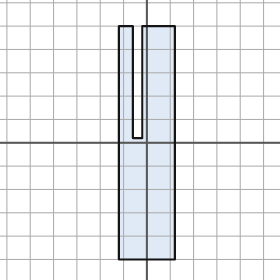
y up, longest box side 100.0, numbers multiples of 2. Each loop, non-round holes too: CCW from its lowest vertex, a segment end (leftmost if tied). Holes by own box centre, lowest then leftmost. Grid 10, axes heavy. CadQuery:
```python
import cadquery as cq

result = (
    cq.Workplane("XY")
    .moveTo(-12.0, -50.0)
    .lineTo(12.0, -50.0)
    .lineTo(12.0, 50.0)
    .lineTo(-2.0, 50.0)
    .lineTo(-2.0, 2.0)
    .lineTo(-6.0, 2.0)
    .lineTo(-6.0, 50.0)
    .lineTo(-12.0, 50.0)
    .close()
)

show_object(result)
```